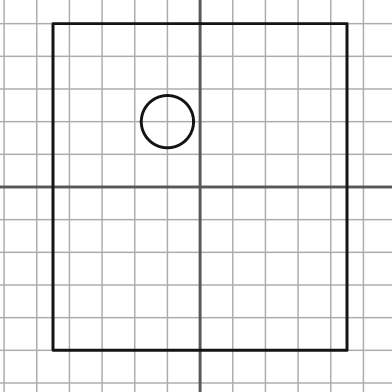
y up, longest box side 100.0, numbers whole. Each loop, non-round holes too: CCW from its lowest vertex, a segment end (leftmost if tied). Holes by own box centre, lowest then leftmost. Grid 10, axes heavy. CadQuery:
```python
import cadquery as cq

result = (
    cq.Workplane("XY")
    .moveTo(-45.0, -50.0)
    .lineTo(45.0, -50.0)
    .lineTo(45.0, 50.0)
    .lineTo(-45.0, 50.0)
    .close()
    .moveTo(-10.0, 20.0)
    .circle(8.0)
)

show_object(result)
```